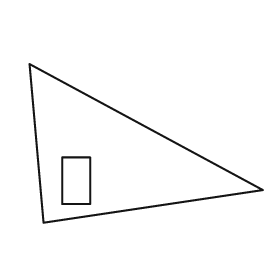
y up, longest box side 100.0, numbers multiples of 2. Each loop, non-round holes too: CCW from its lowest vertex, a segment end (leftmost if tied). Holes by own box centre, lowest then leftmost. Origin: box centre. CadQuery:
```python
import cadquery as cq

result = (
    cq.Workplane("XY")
    .moveTo(-44.0, -34.0)
    .lineTo(50.0, -20.0)
    .lineTo(-50.0, 34.0)
    .close()
    .moveTo(-36.0, -26.0)
    .lineTo(-24.0, -26.0)
    .lineTo(-24.0, -6.0)
    .lineTo(-36.0, -6.0)
    .close()
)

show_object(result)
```